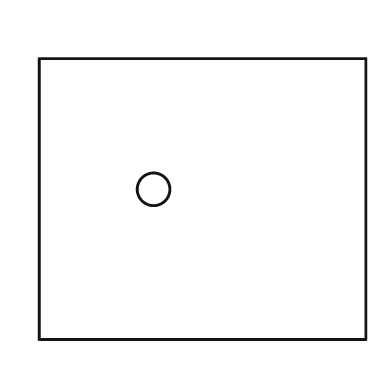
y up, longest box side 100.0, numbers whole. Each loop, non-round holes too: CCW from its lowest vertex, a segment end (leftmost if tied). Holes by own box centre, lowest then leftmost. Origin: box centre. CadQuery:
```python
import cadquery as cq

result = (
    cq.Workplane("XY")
    .moveTo(-50.0, -43.0)
    .lineTo(50.0, -43.0)
    .lineTo(50.0, 43.0)
    .lineTo(-50.0, 43.0)
    .close()
    .moveTo(-15.0, 3.0)
    .circle(5.0)
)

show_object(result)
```